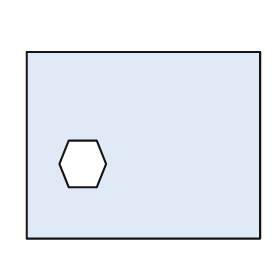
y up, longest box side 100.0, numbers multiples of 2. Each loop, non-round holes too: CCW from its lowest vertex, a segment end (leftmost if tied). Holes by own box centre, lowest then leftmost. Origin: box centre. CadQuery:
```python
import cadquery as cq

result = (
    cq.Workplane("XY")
    .moveTo(-50.0, -40.0)
    .lineTo(50.0, -40.0)
    .lineTo(50.0, 40.0)
    .lineTo(-50.0, 40.0)
    .close()
    .moveTo(-32.0, -18.0)
    .lineTo(-20.0, -18.0)
    .lineTo(-16.0, -8.0)
    .lineTo(-20.0, 2.0)
    .lineTo(-32.0, 2.0)
    .lineTo(-36.0, -8.0)
    .close()
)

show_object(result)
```